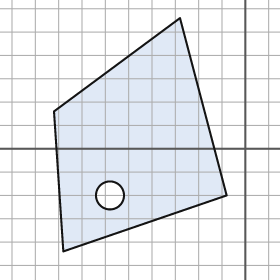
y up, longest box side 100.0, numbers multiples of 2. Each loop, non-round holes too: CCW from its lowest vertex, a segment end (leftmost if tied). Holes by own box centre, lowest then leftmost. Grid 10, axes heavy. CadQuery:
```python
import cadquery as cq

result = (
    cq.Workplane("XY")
    .moveTo(-78.0, -44.0)
    .lineTo(-8.0, -20.0)
    .lineTo(-28.0, 56.0)
    .lineTo(-82.0, 16.0)
    .close()
    .moveTo(-58.0, -20.0)
    .circle(6.0)
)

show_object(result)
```